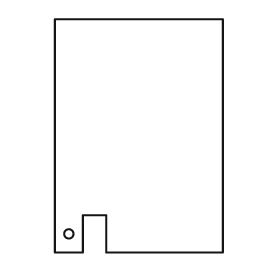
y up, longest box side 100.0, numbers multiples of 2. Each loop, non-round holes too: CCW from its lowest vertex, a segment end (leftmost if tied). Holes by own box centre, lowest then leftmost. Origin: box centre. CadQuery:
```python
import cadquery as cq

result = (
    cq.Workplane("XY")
    .moveTo(-36.0, -50.0)
    .lineTo(-24.0, -50.0)
    .lineTo(-24.0, -34.0)
    .lineTo(-14.0, -34.0)
    .lineTo(-14.0, -50.0)
    .lineTo(36.0, -50.0)
    .lineTo(36.0, 50.0)
    .lineTo(-36.0, 50.0)
    .close()
    .moveTo(-30.0, -42.0)
    .circle(2.0)
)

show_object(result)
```